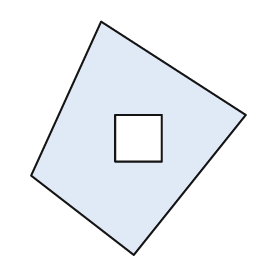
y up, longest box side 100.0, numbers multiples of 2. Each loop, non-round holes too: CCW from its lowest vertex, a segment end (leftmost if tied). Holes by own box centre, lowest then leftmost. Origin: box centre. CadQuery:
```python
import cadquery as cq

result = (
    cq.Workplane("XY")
    .moveTo(-2.0, -50.0)
    .lineTo(46.0, 10.0)
    .lineTo(-16.0, 50.0)
    .lineTo(-46.0, -16.0)
    .close()
    .moveTo(-10.0, -10.0)
    .lineTo(10.0, -10.0)
    .lineTo(10.0, 10.0)
    .lineTo(-10.0, 10.0)
    .close()
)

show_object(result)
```